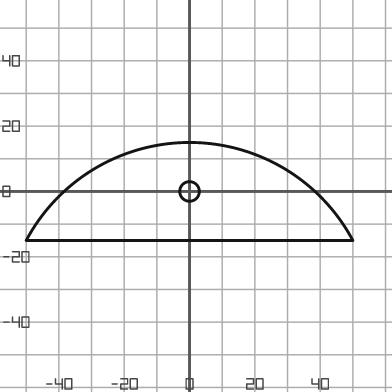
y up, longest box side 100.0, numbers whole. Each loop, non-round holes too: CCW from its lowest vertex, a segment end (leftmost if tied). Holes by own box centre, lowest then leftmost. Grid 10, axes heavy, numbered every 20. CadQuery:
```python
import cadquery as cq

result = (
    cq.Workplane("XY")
    .moveTo(-50.0, -15.0)
    .lineTo(50.0, -15.0)
    .threePointArc((0.0, 15.0), (-50.0, -15.0))
    .close()
    .moveTo(0.0, 0.0)
    .circle(3.0)
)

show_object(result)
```